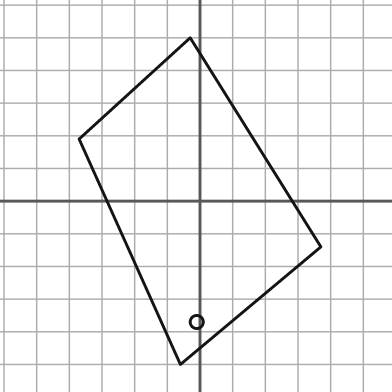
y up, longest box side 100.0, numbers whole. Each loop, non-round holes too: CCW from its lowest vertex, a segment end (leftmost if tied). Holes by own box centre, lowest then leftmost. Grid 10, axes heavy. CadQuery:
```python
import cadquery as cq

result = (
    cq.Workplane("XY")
    .moveTo(-6.0, -50.0)
    .lineTo(37.0, -14.0)
    .lineTo(-3.0, 50.0)
    .lineTo(-37.0, 19.0)
    .close()
    .moveTo(-1.0, -37.0)
    .circle(2.0)
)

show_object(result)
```